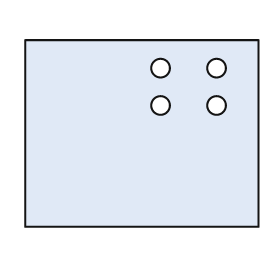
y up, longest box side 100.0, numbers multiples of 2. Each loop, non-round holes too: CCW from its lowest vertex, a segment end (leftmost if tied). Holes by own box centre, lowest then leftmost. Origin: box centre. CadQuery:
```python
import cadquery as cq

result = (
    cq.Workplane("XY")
    .moveTo(-50.0, -40.0)
    .lineTo(50.0, -40.0)
    .lineTo(50.0, 40.0)
    .lineTo(-50.0, 40.0)
    .close()
    .moveTo(8.0, 12.0)
    .circle(4.0)
    .moveTo(32.0, 12.0)
    .circle(4.0)
    .moveTo(8.0, 28.0)
    .circle(4.0)
    .moveTo(32.0, 28.0)
    .circle(4.0)
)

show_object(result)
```